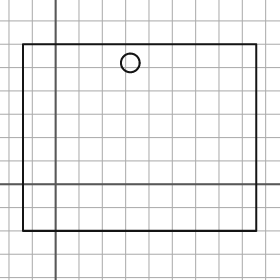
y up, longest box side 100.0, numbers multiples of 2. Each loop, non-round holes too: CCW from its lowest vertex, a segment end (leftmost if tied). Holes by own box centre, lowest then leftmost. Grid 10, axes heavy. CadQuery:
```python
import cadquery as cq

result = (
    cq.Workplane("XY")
    .moveTo(-14.0, -20.0)
    .lineTo(86.0, -20.0)
    .lineTo(86.0, 60.0)
    .lineTo(-14.0, 60.0)
    .close()
    .moveTo(32.0, 52.0)
    .circle(4.0)
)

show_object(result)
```